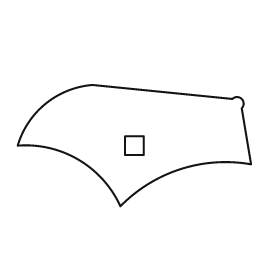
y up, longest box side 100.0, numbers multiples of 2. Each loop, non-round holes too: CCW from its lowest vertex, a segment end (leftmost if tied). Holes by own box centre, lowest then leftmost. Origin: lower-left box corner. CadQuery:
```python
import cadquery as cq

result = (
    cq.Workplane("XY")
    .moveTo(44.0, 0.0)
    .threePointArc((70.0, 16.0), (100.0, 18.0))
    .lineTo(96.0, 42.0)
    .threePointArc((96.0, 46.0), (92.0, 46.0))
    .lineTo(32.0, 52.0)
    .threePointArc((12.0, 44.0), (0.0, 26.0))
    .threePointArc((26.0, 20.0), (44.0, 0.0))
    .close()
    .moveTo(46.0, 22.0)
    .lineTo(54.0, 22.0)
    .lineTo(54.0, 30.0)
    .lineTo(46.0, 30.0)
    .close()
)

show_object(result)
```